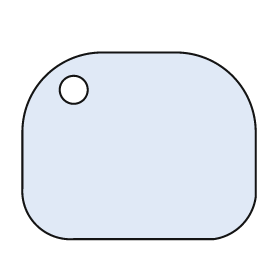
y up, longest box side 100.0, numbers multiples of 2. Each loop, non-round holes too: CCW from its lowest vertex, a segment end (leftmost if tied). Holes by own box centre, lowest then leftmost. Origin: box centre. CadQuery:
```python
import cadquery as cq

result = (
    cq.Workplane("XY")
    .moveTo(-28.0, -40.0)
    .lineTo(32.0, -40.0)
    .threePointArc((44.0, -34.0), (50.0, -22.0))
    .lineTo(50.0, 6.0)
    .threePointArc((40.0, 30.0), (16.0, 40.0))
    .lineTo(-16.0, 40.0)
    .threePointArc((-40.0, 30.0), (-50.0, 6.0))
    .lineTo(-50.0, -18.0)
    .threePointArc((-44.0, -34.0), (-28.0, -40.0))
    .close()
    .moveTo(-28.0, 24.0)
    .circle(6.0)
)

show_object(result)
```